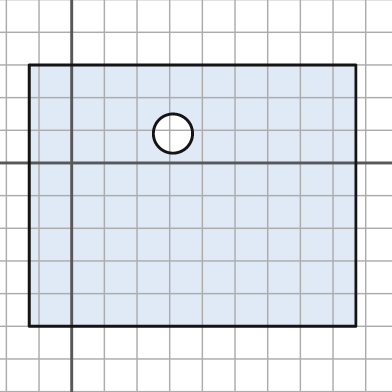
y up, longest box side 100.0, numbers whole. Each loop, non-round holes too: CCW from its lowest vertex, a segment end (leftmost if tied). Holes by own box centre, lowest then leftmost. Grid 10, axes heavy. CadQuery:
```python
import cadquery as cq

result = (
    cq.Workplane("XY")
    .moveTo(-13.0, -50.0)
    .lineTo(87.0, -50.0)
    .lineTo(87.0, 30.0)
    .lineTo(-13.0, 30.0)
    .close()
    .moveTo(31.0, 9.0)
    .circle(6.0)
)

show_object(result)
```